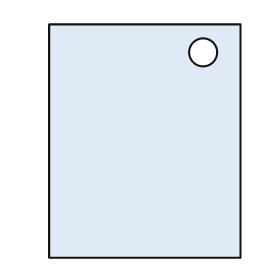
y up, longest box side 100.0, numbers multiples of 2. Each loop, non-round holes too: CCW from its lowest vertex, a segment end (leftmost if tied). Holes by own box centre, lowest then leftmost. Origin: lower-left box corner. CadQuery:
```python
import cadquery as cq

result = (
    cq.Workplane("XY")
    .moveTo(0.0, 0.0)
    .lineTo(82.0, 0.0)
    .lineTo(82.0, 100.0)
    .lineTo(0.0, 100.0)
    .close()
    .moveTo(66.0, 88.0)
    .circle(6.0)
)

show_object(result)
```